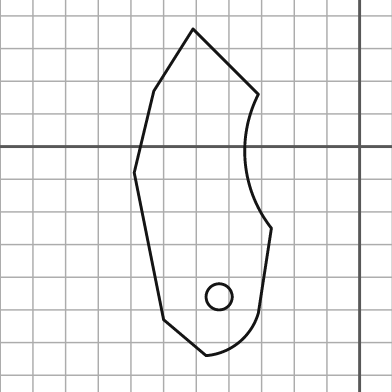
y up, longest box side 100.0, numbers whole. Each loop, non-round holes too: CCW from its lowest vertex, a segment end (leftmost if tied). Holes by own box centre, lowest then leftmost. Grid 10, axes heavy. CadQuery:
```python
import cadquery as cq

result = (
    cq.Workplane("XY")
    .moveTo(-47.0, -64.0)
    .threePointArc((-37.0, -60.0), (-31.0, -51.0))
    .lineTo(-27.0, -25.0)
    .threePointArc((-35.0, -5.0), (-31.0, 16.0))
    .lineTo(-51.0, 36.0)
    .lineTo(-63.0, 17.0)
    .lineTo(-69.0, -8.0)
    .lineTo(-60.0, -53.0)
    .close()
    .moveTo(-43.0, -46.0)
    .circle(4.0)
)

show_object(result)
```